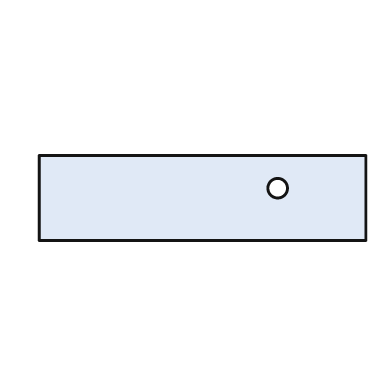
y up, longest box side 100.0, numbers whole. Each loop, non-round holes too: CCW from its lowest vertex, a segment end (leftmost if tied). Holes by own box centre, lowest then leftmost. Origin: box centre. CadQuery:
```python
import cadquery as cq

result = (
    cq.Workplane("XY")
    .moveTo(-50.0, -13.0)
    .lineTo(50.0, -13.0)
    .lineTo(50.0, 13.0)
    .lineTo(-50.0, 13.0)
    .close()
    .moveTo(23.0, 3.0)
    .circle(3.0)
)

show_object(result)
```